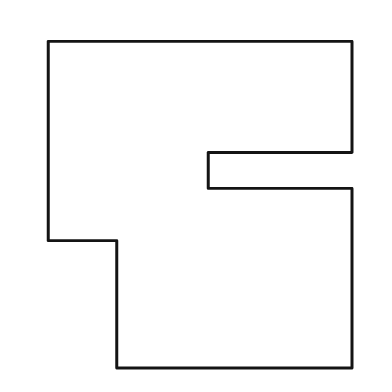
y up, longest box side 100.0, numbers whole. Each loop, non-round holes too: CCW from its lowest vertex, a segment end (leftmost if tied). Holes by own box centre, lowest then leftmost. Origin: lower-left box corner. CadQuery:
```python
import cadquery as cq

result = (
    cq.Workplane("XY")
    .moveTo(21.0, 0.0)
    .lineTo(93.0, 0.0)
    .lineTo(93.0, 55.0)
    .lineTo(49.0, 55.0)
    .lineTo(49.0, 66.0)
    .lineTo(93.0, 66.0)
    .lineTo(93.0, 100.0)
    .lineTo(0.0, 100.0)
    .lineTo(0.0, 39.0)
    .lineTo(21.0, 39.0)
    .close()
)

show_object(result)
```